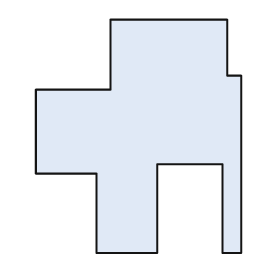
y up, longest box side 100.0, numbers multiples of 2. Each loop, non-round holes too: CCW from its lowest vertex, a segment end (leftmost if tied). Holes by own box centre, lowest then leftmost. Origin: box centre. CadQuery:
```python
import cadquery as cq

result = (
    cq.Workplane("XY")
    .moveTo(-18.0, -50.0)
    .lineTo(8.0, -50.0)
    .lineTo(8.0, -12.0)
    .lineTo(36.0, -12.0)
    .lineTo(36.0, -50.0)
    .lineTo(44.0, -50.0)
    .lineTo(44.0, 26.0)
    .lineTo(38.0, 26.0)
    .lineTo(38.0, 50.0)
    .lineTo(-12.0, 50.0)
    .lineTo(-12.0, 20.0)
    .lineTo(-44.0, 20.0)
    .lineTo(-44.0, -16.0)
    .lineTo(-18.0, -16.0)
    .close()
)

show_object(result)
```